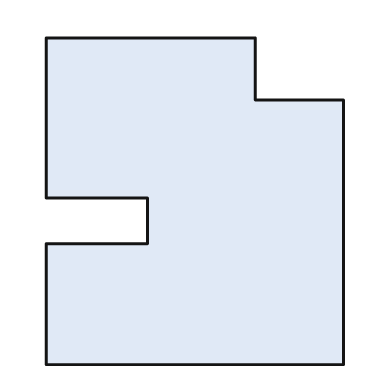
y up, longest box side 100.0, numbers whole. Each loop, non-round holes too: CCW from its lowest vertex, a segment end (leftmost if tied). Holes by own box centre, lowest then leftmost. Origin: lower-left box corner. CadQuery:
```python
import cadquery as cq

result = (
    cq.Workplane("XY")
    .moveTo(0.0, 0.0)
    .lineTo(91.0, 0.0)
    .lineTo(91.0, 81.0)
    .lineTo(64.0, 81.0)
    .lineTo(64.0, 100.0)
    .lineTo(0.0, 100.0)
    .lineTo(0.0, 51.0)
    .lineTo(31.0, 51.0)
    .lineTo(31.0, 37.0)
    .lineTo(0.0, 37.0)
    .close()
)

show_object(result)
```